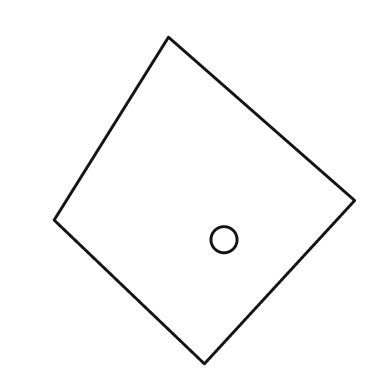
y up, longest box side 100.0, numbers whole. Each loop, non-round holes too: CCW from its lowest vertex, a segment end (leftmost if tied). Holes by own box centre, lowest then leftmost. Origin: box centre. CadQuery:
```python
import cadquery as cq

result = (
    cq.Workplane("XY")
    .moveTo(0.0, -50.0)
    .lineTo(46.0, 0.0)
    .lineTo(-11.0, 50.0)
    .lineTo(-46.0, -6.0)
    .close()
    .moveTo(6.0, -12.0)
    .circle(4.0)
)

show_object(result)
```